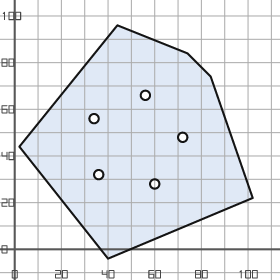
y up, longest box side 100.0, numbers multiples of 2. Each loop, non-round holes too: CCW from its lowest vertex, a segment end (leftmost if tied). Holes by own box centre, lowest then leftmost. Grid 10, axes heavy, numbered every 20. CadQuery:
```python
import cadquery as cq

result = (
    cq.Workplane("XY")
    .moveTo(40.0, -4.0)
    .lineTo(102.0, 22.0)
    .lineTo(84.0, 74.0)
    .lineTo(74.0, 84.0)
    .lineTo(44.0, 96.0)
    .lineTo(2.0, 44.0)
    .close()
    .moveTo(60.0, 28.0)
    .circle(2.0)
    .moveTo(36.0, 32.0)
    .circle(2.0)
    .moveTo(72.0, 48.0)
    .circle(2.0)
    .moveTo(34.0, 56.0)
    .circle(2.0)
    .moveTo(56.0, 66.0)
    .circle(2.0)
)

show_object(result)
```